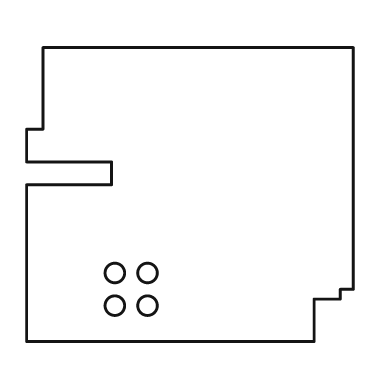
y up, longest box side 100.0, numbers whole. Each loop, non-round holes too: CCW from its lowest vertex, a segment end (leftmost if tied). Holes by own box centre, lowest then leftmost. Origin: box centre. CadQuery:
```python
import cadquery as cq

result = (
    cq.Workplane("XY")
    .moveTo(-50.0, -45.0)
    .lineTo(38.0, -45.0)
    .lineTo(38.0, -32.0)
    .lineTo(46.0, -32.0)
    .lineTo(46.0, -29.0)
    .lineTo(50.0, -29.0)
    .lineTo(50.0, 45.0)
    .lineTo(-45.0, 45.0)
    .lineTo(-45.0, 20.0)
    .lineTo(-50.0, 20.0)
    .lineTo(-50.0, 10.0)
    .lineTo(-24.0, 10.0)
    .lineTo(-24.0, 3.0)
    .lineTo(-50.0, 3.0)
    .close()
    .moveTo(-23.0, -34.0)
    .circle(3.0)
    .moveTo(-13.0, -34.0)
    .circle(3.0)
    .moveTo(-23.0, -24.0)
    .circle(3.0)
    .moveTo(-13.0, -24.0)
    .circle(3.0)
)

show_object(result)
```